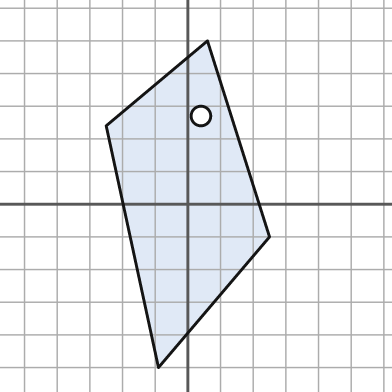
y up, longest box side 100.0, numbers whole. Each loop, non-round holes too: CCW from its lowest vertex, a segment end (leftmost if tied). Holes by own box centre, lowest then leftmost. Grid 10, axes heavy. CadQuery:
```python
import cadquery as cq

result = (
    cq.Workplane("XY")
    .moveTo(-9.0, -50.0)
    .lineTo(25.0, -10.0)
    .lineTo(6.0, 50.0)
    .lineTo(-25.0, 24.0)
    .close()
    .moveTo(4.0, 27.0)
    .circle(3.0)
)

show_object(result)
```